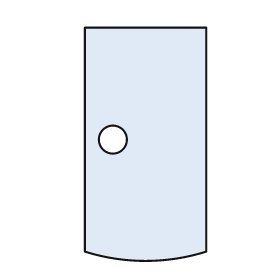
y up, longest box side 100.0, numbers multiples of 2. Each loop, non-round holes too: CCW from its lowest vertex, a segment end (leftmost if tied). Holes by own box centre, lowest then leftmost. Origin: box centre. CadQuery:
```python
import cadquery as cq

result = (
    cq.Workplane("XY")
    .moveTo(-26.0, -46.0)
    .threePointArc((0.0, -50.0), (26.0, -46.0))
    .lineTo(26.0, 50.0)
    .lineTo(-26.0, 50.0)
    .close()
    .moveTo(-14.0, 2.0)
    .circle(6.0)
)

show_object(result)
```